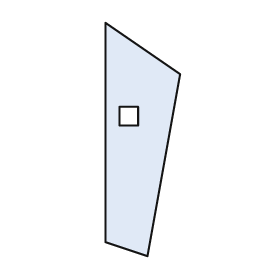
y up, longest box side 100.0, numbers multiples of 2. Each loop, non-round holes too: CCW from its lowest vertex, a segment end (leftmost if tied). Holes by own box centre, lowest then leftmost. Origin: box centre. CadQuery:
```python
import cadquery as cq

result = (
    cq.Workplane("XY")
    .moveTo(2.0, -50.0)
    .lineTo(16.0, 28.0)
    .lineTo(-16.0, 50.0)
    .lineTo(-16.0, -44.0)
    .close()
    .moveTo(-10.0, 6.0)
    .lineTo(-2.0, 6.0)
    .lineTo(-2.0, 14.0)
    .lineTo(-10.0, 14.0)
    .close()
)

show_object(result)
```